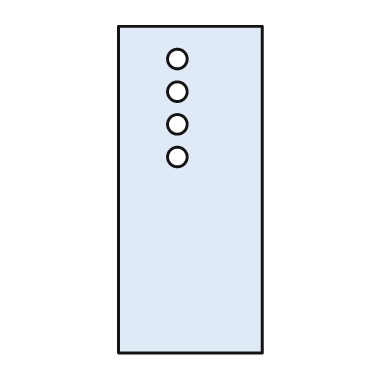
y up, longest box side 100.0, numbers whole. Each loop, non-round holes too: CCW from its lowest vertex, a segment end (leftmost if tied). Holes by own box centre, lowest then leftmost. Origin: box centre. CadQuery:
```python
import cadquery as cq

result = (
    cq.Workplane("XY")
    .moveTo(-22.0, -50.0)
    .lineTo(22.0, -50.0)
    .lineTo(22.0, 50.0)
    .lineTo(-22.0, 50.0)
    .close()
    .moveTo(-4.0, 10.0)
    .circle(3.0)
    .moveTo(-4.0, 20.0)
    .circle(3.0)
    .moveTo(-4.0, 30.0)
    .circle(3.0)
    .moveTo(-4.0, 40.0)
    .circle(3.0)
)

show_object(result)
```